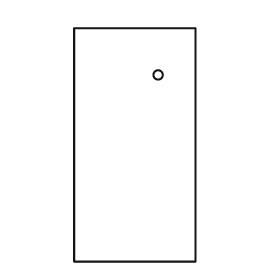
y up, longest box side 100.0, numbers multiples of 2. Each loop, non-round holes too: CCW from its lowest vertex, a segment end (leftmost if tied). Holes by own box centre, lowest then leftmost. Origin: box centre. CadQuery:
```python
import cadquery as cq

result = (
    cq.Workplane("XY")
    .moveTo(-26.0, -50.0)
    .lineTo(26.0, -50.0)
    .lineTo(26.0, 50.0)
    .lineTo(-26.0, 50.0)
    .close()
    .moveTo(10.0, 30.0)
    .circle(2.0)
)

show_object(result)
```